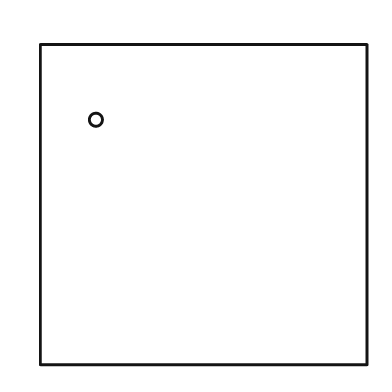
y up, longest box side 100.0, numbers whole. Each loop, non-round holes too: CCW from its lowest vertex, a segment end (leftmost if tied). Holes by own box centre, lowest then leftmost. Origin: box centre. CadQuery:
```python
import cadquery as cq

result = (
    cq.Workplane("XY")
    .moveTo(-50.0, -49.0)
    .lineTo(50.0, -49.0)
    .lineTo(50.0, 49.0)
    .lineTo(-50.0, 49.0)
    .close()
    .moveTo(-33.0, 26.0)
    .circle(2.0)
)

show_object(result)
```